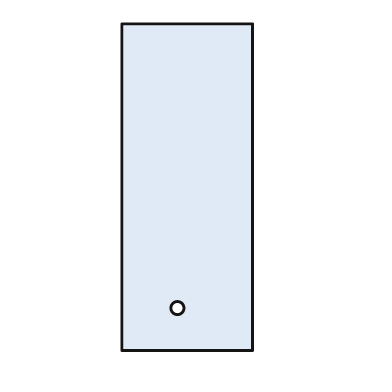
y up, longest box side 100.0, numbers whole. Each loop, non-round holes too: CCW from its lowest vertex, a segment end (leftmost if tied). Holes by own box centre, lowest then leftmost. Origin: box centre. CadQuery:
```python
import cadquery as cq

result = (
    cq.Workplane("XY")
    .moveTo(-20.0, -50.0)
    .lineTo(20.0, -50.0)
    .lineTo(20.0, 50.0)
    .lineTo(-20.0, 50.0)
    .close()
    .moveTo(-3.0, -37.0)
    .circle(2.0)
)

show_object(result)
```